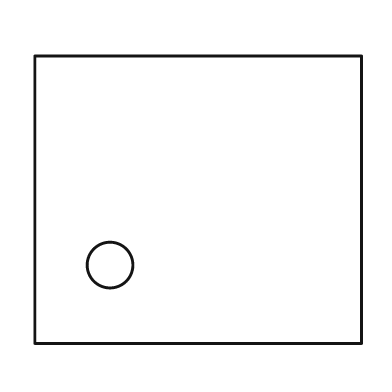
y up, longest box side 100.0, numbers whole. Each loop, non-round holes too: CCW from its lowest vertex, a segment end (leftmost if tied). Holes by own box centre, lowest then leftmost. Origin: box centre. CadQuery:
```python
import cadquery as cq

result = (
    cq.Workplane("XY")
    .moveTo(-50.0, -44.0)
    .lineTo(50.0, -44.0)
    .lineTo(50.0, 44.0)
    .lineTo(-50.0, 44.0)
    .close()
    .moveTo(-27.0, -20.0)
    .circle(7.0)
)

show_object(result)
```